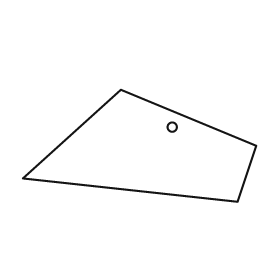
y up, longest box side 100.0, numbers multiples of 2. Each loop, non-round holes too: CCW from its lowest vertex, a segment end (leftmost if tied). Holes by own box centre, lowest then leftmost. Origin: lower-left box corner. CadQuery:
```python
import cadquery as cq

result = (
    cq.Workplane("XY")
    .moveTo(92.0, 0.0)
    .lineTo(100.0, 24.0)
    .lineTo(42.0, 48.0)
    .lineTo(0.0, 10.0)
    .close()
    .moveTo(64.0, 32.0)
    .circle(2.0)
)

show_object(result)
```